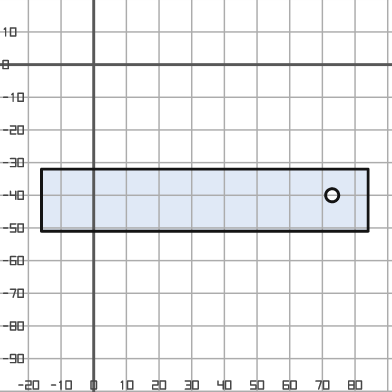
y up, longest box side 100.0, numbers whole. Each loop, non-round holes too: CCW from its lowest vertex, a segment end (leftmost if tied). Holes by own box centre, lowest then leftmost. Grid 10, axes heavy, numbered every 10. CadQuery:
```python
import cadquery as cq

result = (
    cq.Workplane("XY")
    .moveTo(-16.0, -51.0)
    .lineTo(84.0, -51.0)
    .lineTo(84.0, -32.0)
    .lineTo(-16.0, -32.0)
    .close()
    .moveTo(73.0, -40.0)
    .circle(2.0)
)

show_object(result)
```